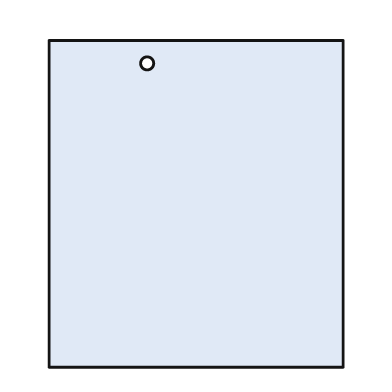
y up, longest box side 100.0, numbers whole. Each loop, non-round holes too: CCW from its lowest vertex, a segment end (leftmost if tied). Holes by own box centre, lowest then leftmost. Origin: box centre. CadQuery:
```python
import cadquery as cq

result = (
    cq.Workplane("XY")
    .moveTo(-45.0, -50.0)
    .lineTo(45.0, -50.0)
    .lineTo(45.0, 50.0)
    .lineTo(-45.0, 50.0)
    .close()
    .moveTo(-15.0, 43.0)
    .circle(2.0)
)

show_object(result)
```